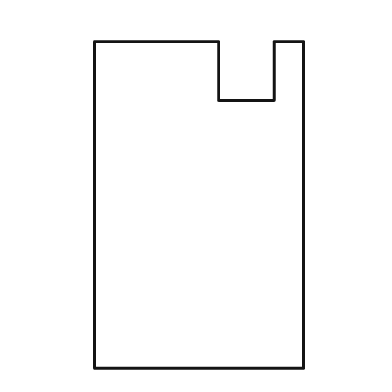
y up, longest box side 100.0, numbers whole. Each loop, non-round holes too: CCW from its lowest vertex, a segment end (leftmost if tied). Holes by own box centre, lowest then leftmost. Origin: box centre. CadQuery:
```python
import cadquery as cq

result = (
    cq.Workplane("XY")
    .moveTo(-32.0, -50.0)
    .lineTo(32.0, -50.0)
    .lineTo(32.0, 50.0)
    .lineTo(23.0, 50.0)
    .lineTo(23.0, 32.0)
    .lineTo(6.0, 32.0)
    .lineTo(6.0, 50.0)
    .lineTo(-32.0, 50.0)
    .close()
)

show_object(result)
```